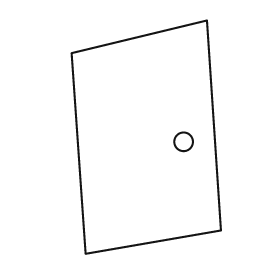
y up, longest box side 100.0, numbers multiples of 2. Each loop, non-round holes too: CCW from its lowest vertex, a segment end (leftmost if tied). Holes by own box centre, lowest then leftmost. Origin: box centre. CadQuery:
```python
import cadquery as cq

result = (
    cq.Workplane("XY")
    .moveTo(-26.0, -50.0)
    .lineTo(32.0, -40.0)
    .lineTo(26.0, 50.0)
    .lineTo(-32.0, 36.0)
    .close()
    .moveTo(16.0, -2.0)
    .circle(4.0)
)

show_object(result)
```